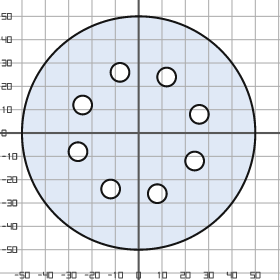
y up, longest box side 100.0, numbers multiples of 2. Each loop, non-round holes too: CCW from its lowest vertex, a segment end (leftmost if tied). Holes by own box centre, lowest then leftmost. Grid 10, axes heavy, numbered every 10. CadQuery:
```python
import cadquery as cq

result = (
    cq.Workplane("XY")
    .moveTo(0.0, 0.0)
    .circle(50.0)
    .moveTo(8.0, -26.0)
    .circle(4.0)
    .moveTo(-12.0, -24.0)
    .circle(4.0)
    .moveTo(24.0, -12.0)
    .circle(4.0)
    .moveTo(-26.0, -8.0)
    .circle(4.0)
    .moveTo(26.0, 8.0)
    .circle(4.0)
    .moveTo(-24.0, 12.0)
    .circle(4.0)
    .moveTo(12.0, 24.0)
    .circle(4.0)
    .moveTo(-8.0, 26.0)
    .circle(4.0)
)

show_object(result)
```